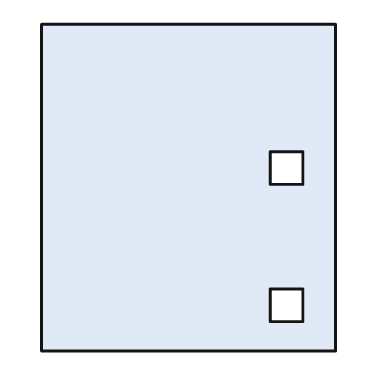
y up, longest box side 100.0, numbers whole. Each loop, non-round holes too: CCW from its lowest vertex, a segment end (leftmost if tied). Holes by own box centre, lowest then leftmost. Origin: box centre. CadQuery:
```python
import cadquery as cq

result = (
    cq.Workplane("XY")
    .moveTo(-45.0, -50.0)
    .lineTo(45.0, -50.0)
    .lineTo(45.0, 50.0)
    .lineTo(-45.0, 50.0)
    .close()
    .moveTo(25.0, -41.0)
    .lineTo(35.0, -41.0)
    .lineTo(35.0, -31.0)
    .lineTo(25.0, -31.0)
    .close()
    .moveTo(25.0, 1.0)
    .lineTo(35.0, 1.0)
    .lineTo(35.0, 11.0)
    .lineTo(25.0, 11.0)
    .close()
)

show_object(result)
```